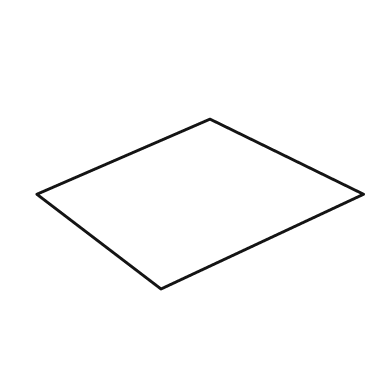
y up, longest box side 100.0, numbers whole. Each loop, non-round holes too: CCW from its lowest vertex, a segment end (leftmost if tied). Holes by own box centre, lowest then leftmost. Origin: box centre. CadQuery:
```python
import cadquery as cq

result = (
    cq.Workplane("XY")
    .moveTo(-12.0, -26.0)
    .lineTo(50.0, 3.0)
    .lineTo(3.0, 26.0)
    .lineTo(-50.0, 3.0)
    .close()
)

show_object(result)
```